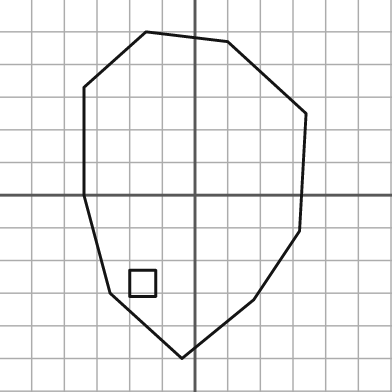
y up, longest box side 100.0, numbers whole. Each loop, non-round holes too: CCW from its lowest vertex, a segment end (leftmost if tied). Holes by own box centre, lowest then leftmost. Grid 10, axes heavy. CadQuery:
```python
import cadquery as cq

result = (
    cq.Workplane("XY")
    .moveTo(-4.0, -50.0)
    .lineTo(18.0, -32.0)
    .lineTo(32.0, -11.0)
    .lineTo(34.0, 25.0)
    .lineTo(10.0, 47.0)
    .lineTo(-15.0, 50.0)
    .lineTo(-34.0, 33.0)
    .lineTo(-34.0, 0.0)
    .lineTo(-26.0, -30.0)
    .close()
    .moveTo(-20.0, -31.0)
    .lineTo(-12.0, -31.0)
    .lineTo(-12.0, -23.0)
    .lineTo(-20.0, -23.0)
    .close()
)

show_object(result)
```